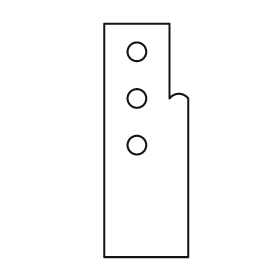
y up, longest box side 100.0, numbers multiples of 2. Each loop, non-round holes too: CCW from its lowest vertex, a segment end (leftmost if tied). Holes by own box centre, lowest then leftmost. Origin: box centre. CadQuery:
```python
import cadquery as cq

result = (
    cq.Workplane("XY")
    .moveTo(-18.0, -50.0)
    .lineTo(18.0, -50.0)
    .lineTo(18.0, 18.0)
    .threePointArc((14.0, 20.0), (10.0, 18.0))
    .lineTo(10.0, 50.0)
    .lineTo(-18.0, 50.0)
    .close()
    .moveTo(-4.0, -2.0)
    .circle(4.0)
    .moveTo(-4.0, 18.0)
    .circle(4.0)
    .moveTo(-4.0, 38.0)
    .circle(4.0)
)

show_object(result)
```